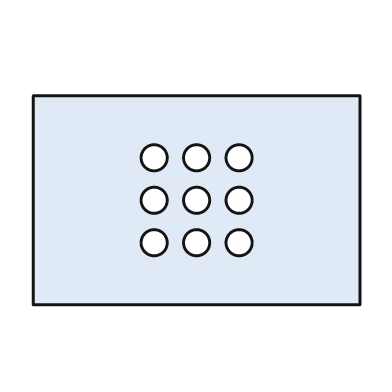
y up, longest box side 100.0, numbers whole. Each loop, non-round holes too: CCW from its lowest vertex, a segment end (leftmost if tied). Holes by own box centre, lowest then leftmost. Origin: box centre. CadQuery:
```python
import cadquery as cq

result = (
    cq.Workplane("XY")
    .moveTo(-50.0, -32.0)
    .lineTo(50.0, -32.0)
    .lineTo(50.0, 32.0)
    .lineTo(-50.0, 32.0)
    .close()
    .moveTo(-13.0, -13.0)
    .circle(4.0)
    .moveTo(0.0, -13.0)
    .circle(4.0)
    .moveTo(13.0, -13.0)
    .circle(4.0)
    .moveTo(-13.0, 0.0)
    .circle(4.0)
    .moveTo(0.0, 0.0)
    .circle(4.0)
    .moveTo(13.0, 0.0)
    .circle(4.0)
    .moveTo(-13.0, 13.0)
    .circle(4.0)
    .moveTo(0.0, 13.0)
    .circle(4.0)
    .moveTo(13.0, 13.0)
    .circle(4.0)
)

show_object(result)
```